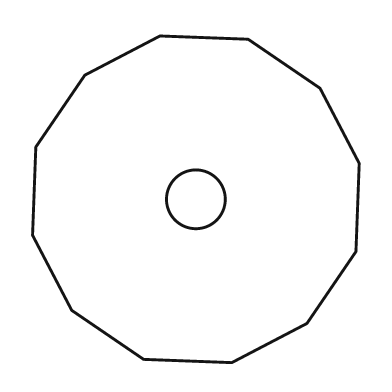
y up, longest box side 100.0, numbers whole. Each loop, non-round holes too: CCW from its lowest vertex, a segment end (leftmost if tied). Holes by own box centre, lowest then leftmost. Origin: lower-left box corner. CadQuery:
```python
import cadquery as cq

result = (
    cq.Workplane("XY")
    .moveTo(61.0, 0.0)
    .lineTo(84.0, 12.0)
    .lineTo(99.0, 34.0)
    .lineTo(100.0, 61.0)
    .lineTo(88.0, 84.0)
    .lineTo(66.0, 99.0)
    .lineTo(39.0, 100.0)
    .lineTo(16.0, 88.0)
    .lineTo(1.0, 66.0)
    .lineTo(0.0, 39.0)
    .lineTo(12.0, 16.0)
    .lineTo(34.0, 1.0)
    .close()
    .moveTo(50.0, 50.0)
    .circle(9.0)
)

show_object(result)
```